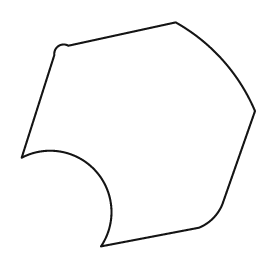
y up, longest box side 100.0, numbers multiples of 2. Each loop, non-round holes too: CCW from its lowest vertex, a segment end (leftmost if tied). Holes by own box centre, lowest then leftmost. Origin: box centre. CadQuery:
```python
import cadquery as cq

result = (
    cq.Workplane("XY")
    .moveTo(-16.0, -48.0)
    .lineTo(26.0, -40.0)
    .threePointArc((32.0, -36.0), (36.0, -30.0))
    .lineTo(50.0, 10.0)
    .threePointArc((36.0, 32.0), (16.0, 48.0))
    .lineTo(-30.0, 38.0)
    .threePointArc((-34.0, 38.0), (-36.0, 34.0))
    .lineTo(-50.0, -10.0)
    .threePointArc((-18.0, -16.0), (-16.0, -48.0))
    .close()
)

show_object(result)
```